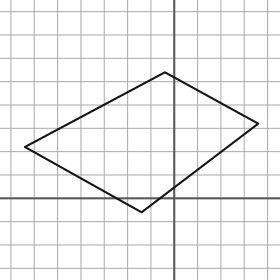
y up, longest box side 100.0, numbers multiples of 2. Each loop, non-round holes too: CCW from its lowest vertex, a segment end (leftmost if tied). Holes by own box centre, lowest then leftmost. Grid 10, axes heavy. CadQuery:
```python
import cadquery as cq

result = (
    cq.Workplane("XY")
    .moveTo(-14.0, -6.0)
    .lineTo(36.0, 32.0)
    .lineTo(-4.0, 54.0)
    .lineTo(-64.0, 22.0)
    .close()
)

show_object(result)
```